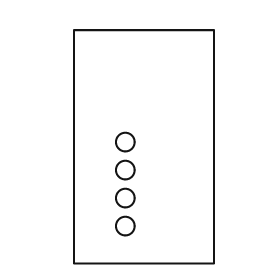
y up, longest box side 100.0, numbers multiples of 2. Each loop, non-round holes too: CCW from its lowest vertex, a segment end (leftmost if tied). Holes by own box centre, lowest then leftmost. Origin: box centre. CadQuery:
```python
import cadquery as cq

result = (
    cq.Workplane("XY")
    .moveTo(-30.0, -50.0)
    .lineTo(30.0, -50.0)
    .lineTo(30.0, 50.0)
    .lineTo(-30.0, 50.0)
    .close()
    .moveTo(-8.0, -34.0)
    .circle(4.0)
    .moveTo(-8.0, -22.0)
    .circle(4.0)
    .moveTo(-8.0, -10.0)
    .circle(4.0)
    .moveTo(-8.0, 2.0)
    .circle(4.0)
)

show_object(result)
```